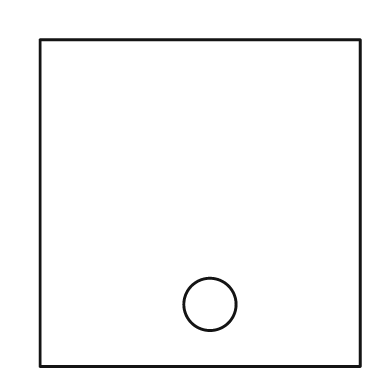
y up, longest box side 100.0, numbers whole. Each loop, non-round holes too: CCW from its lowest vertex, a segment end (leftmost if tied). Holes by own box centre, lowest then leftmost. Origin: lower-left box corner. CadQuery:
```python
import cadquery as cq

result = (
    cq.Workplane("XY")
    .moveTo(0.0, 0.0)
    .lineTo(98.0, 0.0)
    .lineTo(98.0, 100.0)
    .lineTo(0.0, 100.0)
    .close()
    .moveTo(52.0, 19.0)
    .circle(8.0)
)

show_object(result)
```